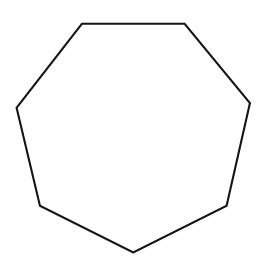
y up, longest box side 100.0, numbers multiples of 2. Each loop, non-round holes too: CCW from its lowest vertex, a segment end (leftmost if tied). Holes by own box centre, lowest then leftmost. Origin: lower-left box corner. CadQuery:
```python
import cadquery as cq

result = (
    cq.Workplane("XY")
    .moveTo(50.0, 0.0)
    .lineTo(90.0, 20.0)
    .lineTo(100.0, 64.0)
    .lineTo(72.0, 98.0)
    .lineTo(28.0, 98.0)
    .lineTo(0.0, 62.0)
    .lineTo(10.0, 20.0)
    .close()
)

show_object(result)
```